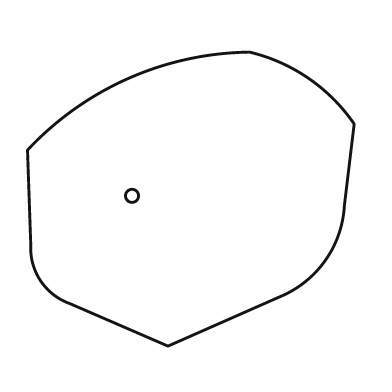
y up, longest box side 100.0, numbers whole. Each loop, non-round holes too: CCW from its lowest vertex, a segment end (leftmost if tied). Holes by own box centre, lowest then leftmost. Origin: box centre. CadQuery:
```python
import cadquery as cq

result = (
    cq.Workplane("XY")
    .moveTo(-7.0, -45.0)
    .lineTo(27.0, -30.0)
    .threePointArc((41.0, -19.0), (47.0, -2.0))
    .lineTo(50.0, 23.0)
    .threePointArc((36.0, 37.0), (18.0, 45.0))
    .threePointArc((-19.0, 37.0), (-50.0, 15.0))
    .lineTo(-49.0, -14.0)
    .threePointArc((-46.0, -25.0), (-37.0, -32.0))
    .close()
    .moveTo(-18.0, 1.0)
    .circle(2.0)
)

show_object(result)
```